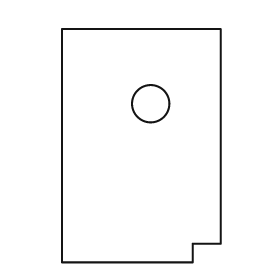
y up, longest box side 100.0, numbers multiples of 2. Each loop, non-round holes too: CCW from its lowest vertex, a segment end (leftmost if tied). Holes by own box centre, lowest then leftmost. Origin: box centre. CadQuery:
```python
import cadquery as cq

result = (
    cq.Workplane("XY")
    .moveTo(-34.0, -50.0)
    .lineTo(22.0, -50.0)
    .lineTo(22.0, -42.0)
    .lineTo(34.0, -42.0)
    .lineTo(34.0, 50.0)
    .lineTo(-34.0, 50.0)
    .close()
    .moveTo(4.0, 18.0)
    .circle(8.0)
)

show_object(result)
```